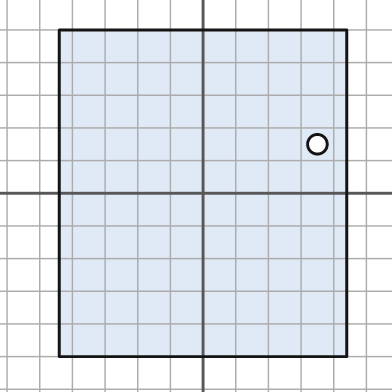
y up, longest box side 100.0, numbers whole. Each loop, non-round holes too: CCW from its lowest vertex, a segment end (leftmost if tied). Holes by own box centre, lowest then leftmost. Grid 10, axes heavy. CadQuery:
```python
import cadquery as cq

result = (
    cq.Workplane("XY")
    .moveTo(-44.0, -50.0)
    .lineTo(44.0, -50.0)
    .lineTo(44.0, 50.0)
    .lineTo(-44.0, 50.0)
    .close()
    .moveTo(35.0, 15.0)
    .circle(3.0)
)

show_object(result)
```